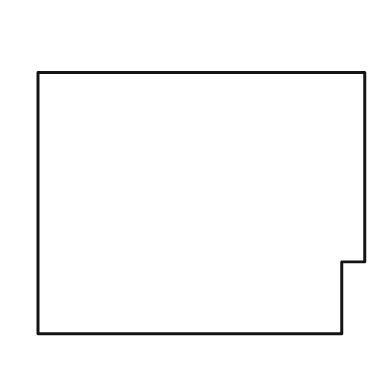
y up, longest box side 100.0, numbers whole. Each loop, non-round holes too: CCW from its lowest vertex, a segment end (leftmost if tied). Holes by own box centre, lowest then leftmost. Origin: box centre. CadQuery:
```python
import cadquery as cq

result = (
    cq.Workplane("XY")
    .moveTo(-50.0, -40.0)
    .lineTo(43.0, -40.0)
    .lineTo(43.0, -18.0)
    .lineTo(50.0, -18.0)
    .lineTo(50.0, 40.0)
    .lineTo(-50.0, 40.0)
    .close()
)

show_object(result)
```